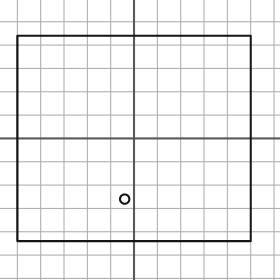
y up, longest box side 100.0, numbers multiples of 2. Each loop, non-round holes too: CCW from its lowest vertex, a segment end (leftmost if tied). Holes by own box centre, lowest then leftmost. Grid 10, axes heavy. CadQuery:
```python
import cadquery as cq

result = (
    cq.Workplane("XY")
    .moveTo(-50.0, -44.0)
    .lineTo(50.0, -44.0)
    .lineTo(50.0, 44.0)
    .lineTo(-50.0, 44.0)
    .close()
    .moveTo(-4.0, -26.0)
    .circle(2.0)
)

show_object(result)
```